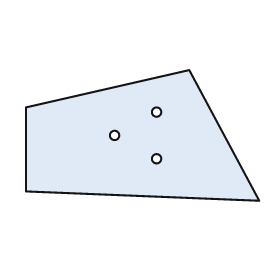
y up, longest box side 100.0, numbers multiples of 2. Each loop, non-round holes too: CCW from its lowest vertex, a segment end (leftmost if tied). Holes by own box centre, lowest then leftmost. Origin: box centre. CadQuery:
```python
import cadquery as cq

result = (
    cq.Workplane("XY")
    .moveTo(50.0, -28.0)
    .lineTo(20.0, 28.0)
    .lineTo(-50.0, 12.0)
    .lineTo(-50.0, -24.0)
    .close()
    .moveTo(6.0, -10.0)
    .circle(2.0)
    .moveTo(-12.0, 0.0)
    .circle(2.0)
    .moveTo(6.0, 10.0)
    .circle(2.0)
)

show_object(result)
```